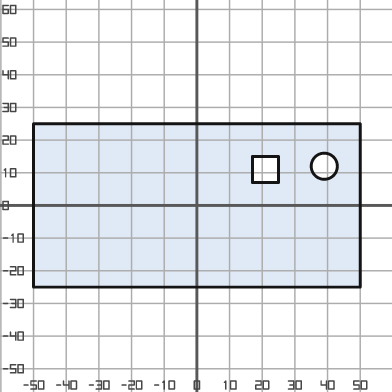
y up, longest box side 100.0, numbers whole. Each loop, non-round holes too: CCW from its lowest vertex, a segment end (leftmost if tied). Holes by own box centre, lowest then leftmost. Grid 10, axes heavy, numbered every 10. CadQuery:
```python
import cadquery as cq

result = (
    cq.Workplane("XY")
    .moveTo(-50.0, -25.0)
    .lineTo(50.0, -25.0)
    .lineTo(50.0, 25.0)
    .lineTo(-50.0, 25.0)
    .close()
    .moveTo(17.0, 7.0)
    .lineTo(25.0, 7.0)
    .lineTo(25.0, 15.0)
    .lineTo(17.0, 15.0)
    .close()
    .moveTo(39.0, 12.0)
    .circle(4.0)
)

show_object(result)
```